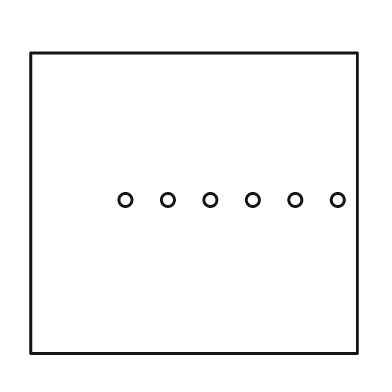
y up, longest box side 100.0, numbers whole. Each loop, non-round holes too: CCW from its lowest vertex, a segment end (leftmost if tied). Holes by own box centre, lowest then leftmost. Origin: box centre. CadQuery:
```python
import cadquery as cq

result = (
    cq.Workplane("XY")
    .moveTo(-50.0, -46.0)
    .lineTo(50.0, -46.0)
    .lineTo(50.0, 46.0)
    .lineTo(-50.0, 46.0)
    .close()
    .moveTo(-21.0, 1.0)
    .circle(2.0)
    .moveTo(-8.0, 1.0)
    .circle(2.0)
    .moveTo(5.0, 1.0)
    .circle(2.0)
    .moveTo(18.0, 1.0)
    .circle(2.0)
    .moveTo(31.0, 1.0)
    .circle(2.0)
    .moveTo(44.0, 1.0)
    .circle(2.0)
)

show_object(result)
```